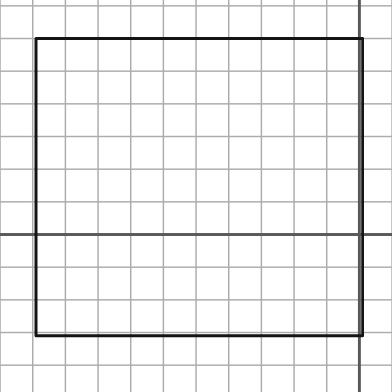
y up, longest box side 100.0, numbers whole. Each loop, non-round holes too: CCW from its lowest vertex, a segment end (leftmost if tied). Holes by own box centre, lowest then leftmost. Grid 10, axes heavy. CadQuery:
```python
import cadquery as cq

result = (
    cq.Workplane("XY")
    .moveTo(-99.0, -31.0)
    .lineTo(1.0, -31.0)
    .lineTo(1.0, 60.0)
    .lineTo(-99.0, 60.0)
    .close()
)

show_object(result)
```